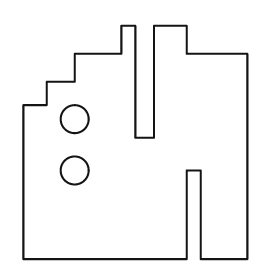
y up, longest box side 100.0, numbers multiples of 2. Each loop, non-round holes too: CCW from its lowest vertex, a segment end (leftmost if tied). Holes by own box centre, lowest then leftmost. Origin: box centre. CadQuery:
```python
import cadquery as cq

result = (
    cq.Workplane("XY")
    .moveTo(-48.0, -50.0)
    .lineTo(22.0, -50.0)
    .lineTo(22.0, -12.0)
    .lineTo(28.0, -12.0)
    .lineTo(28.0, -50.0)
    .lineTo(48.0, -50.0)
    .lineTo(48.0, 38.0)
    .lineTo(22.0, 38.0)
    .lineTo(22.0, 50.0)
    .lineTo(8.0, 50.0)
    .lineTo(8.0, 2.0)
    .lineTo(0.0, 2.0)
    .lineTo(0.0, 50.0)
    .lineTo(-6.0, 50.0)
    .lineTo(-6.0, 38.0)
    .lineTo(-26.0, 38.0)
    .lineTo(-26.0, 26.0)
    .lineTo(-38.0, 26.0)
    .lineTo(-38.0, 16.0)
    .lineTo(-48.0, 16.0)
    .close()
    .moveTo(-26.0, -12.0)
    .circle(6.0)
    .moveTo(-26.0, 10.0)
    .circle(6.0)
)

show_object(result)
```